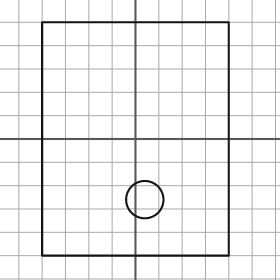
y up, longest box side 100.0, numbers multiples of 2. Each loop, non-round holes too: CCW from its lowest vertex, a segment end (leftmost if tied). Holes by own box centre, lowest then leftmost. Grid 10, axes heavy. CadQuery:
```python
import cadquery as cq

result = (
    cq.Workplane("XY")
    .moveTo(-40.0, -50.0)
    .lineTo(40.0, -50.0)
    .lineTo(40.0, 50.0)
    .lineTo(-40.0, 50.0)
    .close()
    .moveTo(4.0, -26.0)
    .circle(8.0)
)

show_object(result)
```